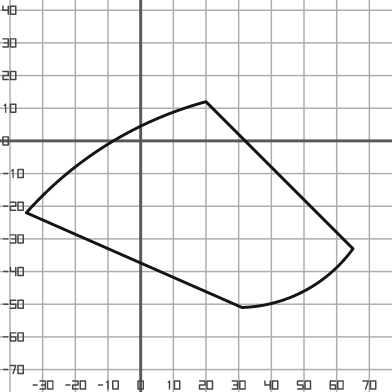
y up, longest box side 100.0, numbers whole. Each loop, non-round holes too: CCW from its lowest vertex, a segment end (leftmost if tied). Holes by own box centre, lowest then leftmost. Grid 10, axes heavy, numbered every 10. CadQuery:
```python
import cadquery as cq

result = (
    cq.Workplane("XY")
    .moveTo(31.0, -51.0)
    .threePointArc((50.0, -46.0), (65.0, -33.0))
    .lineTo(20.0, 12.0)
    .threePointArc((-10.0, -1.0), (-35.0, -22.0))
    .close()
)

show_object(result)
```